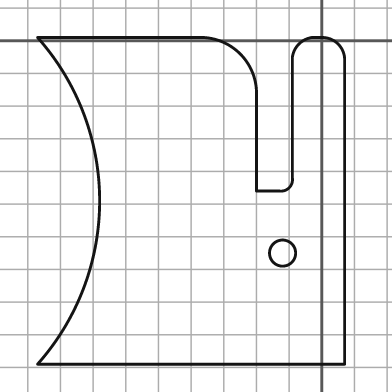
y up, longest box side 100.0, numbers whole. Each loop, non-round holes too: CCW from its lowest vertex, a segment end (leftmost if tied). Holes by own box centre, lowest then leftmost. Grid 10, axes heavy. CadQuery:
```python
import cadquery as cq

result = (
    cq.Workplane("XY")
    .moveTo(-87.0, -99.0)
    .lineTo(7.0, -99.0)
    .lineTo(7.0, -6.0)
    .threePointArc((5.0, -1.0), (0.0, 1.0))
    .lineTo(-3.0, 1.0)
    .threePointArc((-7.0, -1.0), (-9.0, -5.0))
    .lineTo(-9.0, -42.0)
    .threePointArc((-10.0, -45.0), (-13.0, -46.0))
    .lineTo(-20.0, -46.0)
    .lineTo(-20.0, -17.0)
    .threePointArc((-25.0, -4.0), (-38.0, 1.0))
    .lineTo(-87.0, 1.0)
    .threePointArc((-68.0, -49.0), (-87.0, -99.0))
    .close()
    .moveTo(-12.0, -65.0)
    .circle(4.0)
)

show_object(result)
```